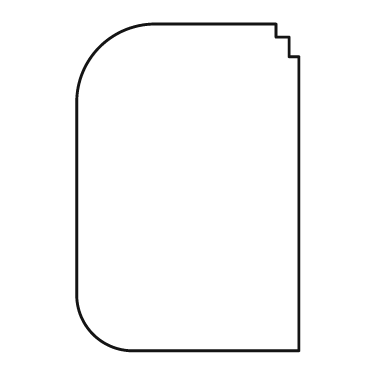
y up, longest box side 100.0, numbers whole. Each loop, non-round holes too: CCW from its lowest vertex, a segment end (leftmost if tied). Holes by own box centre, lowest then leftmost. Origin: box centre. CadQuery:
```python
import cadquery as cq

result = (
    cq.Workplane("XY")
    .moveTo(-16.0, -50.0)
    .lineTo(34.0, -50.0)
    .lineTo(34.0, 40.0)
    .lineTo(31.0, 40.0)
    .lineTo(31.0, 46.0)
    .lineTo(27.0, 46.0)
    .lineTo(27.0, 50.0)
    .lineTo(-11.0, 50.0)
    .threePointArc((-27.0, 43.0), (-34.0, 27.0))
    .lineTo(-34.0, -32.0)
    .threePointArc((-29.0, -45.0), (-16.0, -50.0))
    .close()
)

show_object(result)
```